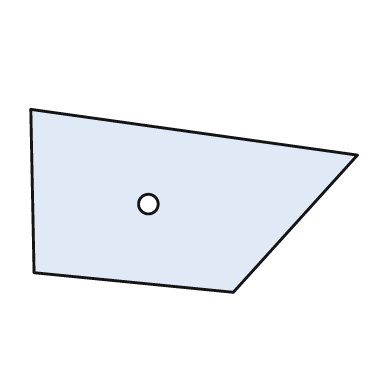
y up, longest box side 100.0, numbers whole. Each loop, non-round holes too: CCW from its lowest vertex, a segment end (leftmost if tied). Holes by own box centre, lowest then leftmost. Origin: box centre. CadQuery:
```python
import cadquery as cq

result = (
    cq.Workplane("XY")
    .moveTo(12.0, -28.0)
    .lineTo(50.0, 14.0)
    .lineTo(-50.0, 28.0)
    .lineTo(-49.0, -22.0)
    .close()
    .moveTo(-14.0, -1.0)
    .circle(3.0)
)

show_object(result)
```